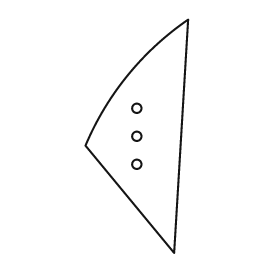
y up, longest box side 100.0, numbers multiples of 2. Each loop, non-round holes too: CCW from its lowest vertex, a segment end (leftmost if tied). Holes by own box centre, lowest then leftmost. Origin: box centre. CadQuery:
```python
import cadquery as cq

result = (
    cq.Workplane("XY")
    .moveTo(16.0, -50.0)
    .lineTo(22.0, 50.0)
    .threePointArc((-4.0, 26.0), (-22.0, -4.0))
    .close()
    .moveTo(0.0, -12.0)
    .circle(2.0)
    .moveTo(0.0, 0.0)
    .circle(2.0)
    .moveTo(0.0, 12.0)
    .circle(2.0)
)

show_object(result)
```